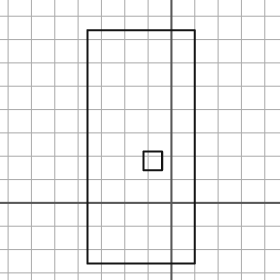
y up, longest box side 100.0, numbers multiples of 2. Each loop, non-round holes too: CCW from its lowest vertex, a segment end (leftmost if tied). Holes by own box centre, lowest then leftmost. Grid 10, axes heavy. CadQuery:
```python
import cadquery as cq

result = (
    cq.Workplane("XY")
    .moveTo(-36.0, -26.0)
    .lineTo(10.0, -26.0)
    .lineTo(10.0, 74.0)
    .lineTo(-36.0, 74.0)
    .close()
    .moveTo(-12.0, 14.0)
    .lineTo(-4.0, 14.0)
    .lineTo(-4.0, 22.0)
    .lineTo(-12.0, 22.0)
    .close()
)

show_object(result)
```